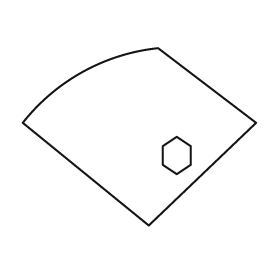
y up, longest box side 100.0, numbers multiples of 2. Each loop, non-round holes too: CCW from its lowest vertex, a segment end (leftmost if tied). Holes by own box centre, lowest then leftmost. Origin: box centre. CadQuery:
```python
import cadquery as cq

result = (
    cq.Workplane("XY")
    .moveTo(4.0, -38.0)
    .lineTo(50.0, 6.0)
    .lineTo(8.0, 38.0)
    .threePointArc((-24.0, 28.0), (-50.0, 6.0))
    .close()
    .moveTo(16.0, -16.0)
    .lineTo(22.0, -12.0)
    .lineTo(22.0, -4.0)
    .lineTo(16.0, 0.0)
    .lineTo(10.0, -4.0)
    .lineTo(10.0, -12.0)
    .close()
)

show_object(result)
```